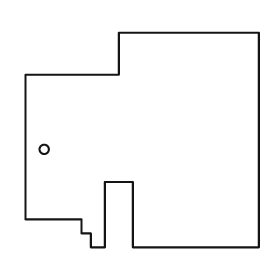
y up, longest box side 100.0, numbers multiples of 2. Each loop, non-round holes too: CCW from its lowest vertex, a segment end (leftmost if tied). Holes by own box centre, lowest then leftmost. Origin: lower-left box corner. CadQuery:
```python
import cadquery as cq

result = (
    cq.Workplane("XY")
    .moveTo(28.0, 0.0)
    .lineTo(34.0, 0.0)
    .lineTo(34.0, 28.0)
    .lineTo(46.0, 28.0)
    .lineTo(46.0, 0.0)
    .lineTo(100.0, 0.0)
    .lineTo(100.0, 92.0)
    .lineTo(40.0, 92.0)
    .lineTo(40.0, 74.0)
    .lineTo(0.0, 74.0)
    .lineTo(0.0, 12.0)
    .lineTo(24.0, 12.0)
    .lineTo(24.0, 6.0)
    .lineTo(28.0, 6.0)
    .close()
    .moveTo(8.0, 42.0)
    .circle(2.0)
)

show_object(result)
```